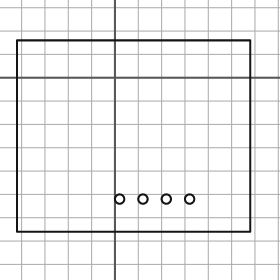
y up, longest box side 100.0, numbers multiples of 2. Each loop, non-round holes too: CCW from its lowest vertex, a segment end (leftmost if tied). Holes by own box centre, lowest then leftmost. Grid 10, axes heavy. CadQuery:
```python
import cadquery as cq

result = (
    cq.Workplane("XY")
    .moveTo(-42.0, -66.0)
    .lineTo(58.0, -66.0)
    .lineTo(58.0, 16.0)
    .lineTo(-42.0, 16.0)
    .close()
    .moveTo(2.0, -52.0)
    .circle(2.0)
    .moveTo(12.0, -52.0)
    .circle(2.0)
    .moveTo(22.0, -52.0)
    .circle(2.0)
    .moveTo(32.0, -52.0)
    .circle(2.0)
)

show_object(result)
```